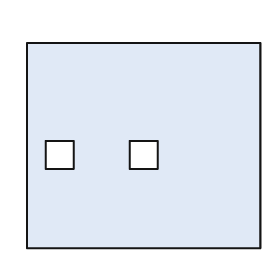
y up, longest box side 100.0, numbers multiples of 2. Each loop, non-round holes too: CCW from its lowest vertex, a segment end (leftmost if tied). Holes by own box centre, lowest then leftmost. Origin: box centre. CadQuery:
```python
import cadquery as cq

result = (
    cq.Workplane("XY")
    .moveTo(-50.0, -44.0)
    .lineTo(50.0, -44.0)
    .lineTo(50.0, 44.0)
    .lineTo(-50.0, 44.0)
    .close()
    .moveTo(-42.0, -10.0)
    .lineTo(-30.0, -10.0)
    .lineTo(-30.0, 2.0)
    .lineTo(-42.0, 2.0)
    .close()
    .moveTo(-6.0, -10.0)
    .lineTo(6.0, -10.0)
    .lineTo(6.0, 2.0)
    .lineTo(-6.0, 2.0)
    .close()
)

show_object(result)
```